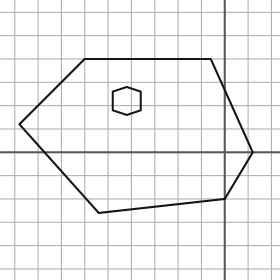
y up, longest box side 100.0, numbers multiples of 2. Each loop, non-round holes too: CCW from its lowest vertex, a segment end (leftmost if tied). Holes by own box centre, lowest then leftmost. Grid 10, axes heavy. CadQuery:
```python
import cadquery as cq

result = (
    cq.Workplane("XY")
    .moveTo(-54.0, -26.0)
    .lineTo(0.0, -20.0)
    .lineTo(12.0, 0.0)
    .lineTo(-6.0, 40.0)
    .lineTo(-60.0, 40.0)
    .lineTo(-88.0, 12.0)
    .close()
    .moveTo(-42.0, 16.0)
    .lineTo(-36.0, 18.0)
    .lineTo(-36.0, 26.0)
    .lineTo(-42.0, 28.0)
    .lineTo(-48.0, 26.0)
    .lineTo(-48.0, 18.0)
    .close()
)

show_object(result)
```